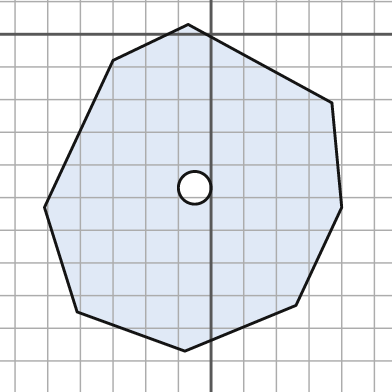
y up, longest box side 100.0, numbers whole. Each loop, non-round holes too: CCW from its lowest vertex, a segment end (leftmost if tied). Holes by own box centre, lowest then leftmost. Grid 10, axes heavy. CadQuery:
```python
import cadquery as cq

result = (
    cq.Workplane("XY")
    .moveTo(-8.0, -97.0)
    .lineTo(26.0, -83.0)
    .lineTo(40.0, -53.0)
    .lineTo(37.0, -21.0)
    .lineTo(-7.0, 3.0)
    .lineTo(-30.0, -8.0)
    .lineTo(-51.0, -53.0)
    .lineTo(-41.0, -85.0)
    .close()
    .moveTo(-5.0, -47.0)
    .circle(5.0)
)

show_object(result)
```